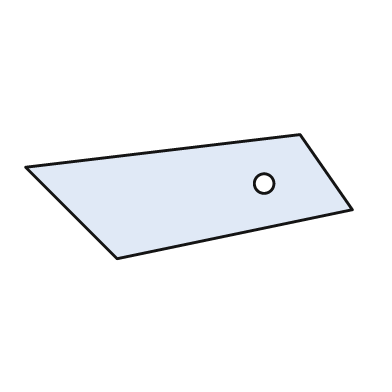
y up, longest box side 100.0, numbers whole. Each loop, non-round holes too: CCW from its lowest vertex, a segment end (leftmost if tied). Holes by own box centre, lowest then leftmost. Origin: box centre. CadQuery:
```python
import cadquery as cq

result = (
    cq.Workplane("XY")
    .moveTo(-22.0, -19.0)
    .lineTo(50.0, -4.0)
    .lineTo(34.0, 19.0)
    .lineTo(-50.0, 9.0)
    .close()
    .moveTo(23.0, 4.0)
    .circle(3.0)
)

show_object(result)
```